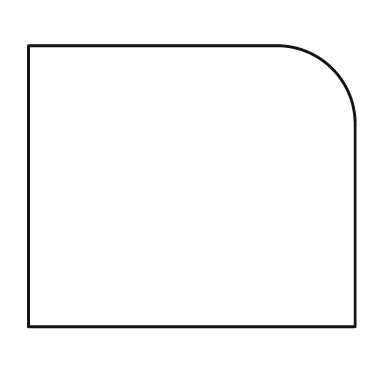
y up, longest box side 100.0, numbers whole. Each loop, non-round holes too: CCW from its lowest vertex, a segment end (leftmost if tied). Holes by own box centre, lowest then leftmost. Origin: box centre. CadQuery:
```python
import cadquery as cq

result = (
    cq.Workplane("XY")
    .moveTo(-50.0, -43.0)
    .lineTo(50.0, -43.0)
    .lineTo(50.0, 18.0)
    .threePointArc((43.0, 36.0), (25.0, 43.0))
    .lineTo(-50.0, 43.0)
    .close()
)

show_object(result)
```